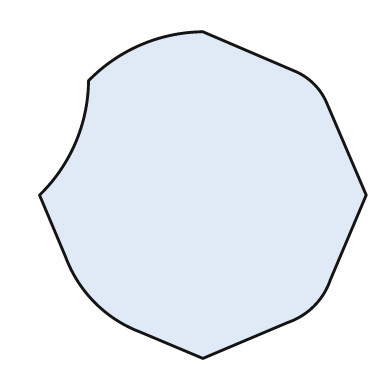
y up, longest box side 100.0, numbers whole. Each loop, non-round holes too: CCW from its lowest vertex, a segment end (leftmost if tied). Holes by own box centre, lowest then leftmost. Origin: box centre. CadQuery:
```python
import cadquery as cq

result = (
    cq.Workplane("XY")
    .moveTo(0.0, -50.0)
    .lineTo(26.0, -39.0)
    .threePointArc((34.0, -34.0), (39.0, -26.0))
    .lineTo(50.0, 0.0)
    .lineTo(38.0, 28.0)
    .threePointArc((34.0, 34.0), (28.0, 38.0))
    .lineTo(0.0, 50.0)
    .threePointArc((-19.0, 46.0), (-35.0, 35.0))
    .threePointArc((-39.0, 16.0), (-50.0, 0.0))
    .lineTo(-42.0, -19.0)
    .threePointArc((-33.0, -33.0), (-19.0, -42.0))
    .close()
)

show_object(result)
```